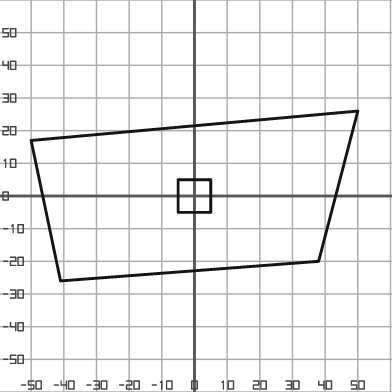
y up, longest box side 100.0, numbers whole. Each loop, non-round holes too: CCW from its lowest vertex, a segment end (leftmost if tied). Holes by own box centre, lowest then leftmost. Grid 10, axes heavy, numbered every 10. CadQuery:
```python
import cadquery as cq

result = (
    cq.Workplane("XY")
    .moveTo(-41.0, -26.0)
    .lineTo(38.0, -20.0)
    .lineTo(50.0, 26.0)
    .lineTo(-50.0, 17.0)
    .close()
    .moveTo(-5.0, -5.0)
    .lineTo(5.0, -5.0)
    .lineTo(5.0, 5.0)
    .lineTo(-5.0, 5.0)
    .close()
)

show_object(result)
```